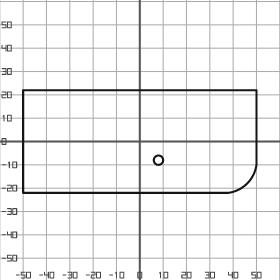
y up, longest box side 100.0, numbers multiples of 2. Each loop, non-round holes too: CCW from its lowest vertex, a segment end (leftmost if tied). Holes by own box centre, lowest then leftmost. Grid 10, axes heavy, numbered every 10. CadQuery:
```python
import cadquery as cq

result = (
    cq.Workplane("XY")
    .moveTo(-50.0, -22.0)
    .lineTo(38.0, -22.0)
    .threePointArc((46.0, -18.0), (50.0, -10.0))
    .lineTo(50.0, 22.0)
    .lineTo(-50.0, 22.0)
    .close()
    .moveTo(8.0, -8.0)
    .circle(2.0)
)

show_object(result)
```